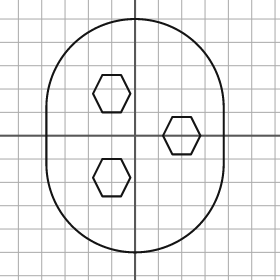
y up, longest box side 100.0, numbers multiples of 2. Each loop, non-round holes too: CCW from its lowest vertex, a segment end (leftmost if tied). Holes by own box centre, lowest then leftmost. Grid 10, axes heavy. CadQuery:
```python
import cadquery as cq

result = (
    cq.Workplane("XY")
    .moveTo(-38.0, -12.0)
    .threePointArc((0.0, -50.0), (38.0, -12.0))
    .lineTo(38.0, 12.0)
    .threePointArc((0.0, 50.0), (-38.0, 12.0))
    .close()
    .moveTo(-14.0, -26.0)
    .lineTo(-6.0, -26.0)
    .lineTo(-2.0, -18.0)
    .lineTo(-6.0, -10.0)
    .lineTo(-14.0, -10.0)
    .lineTo(-18.0, -18.0)
    .close()
    .moveTo(16.0, -8.0)
    .lineTo(24.0, -8.0)
    .lineTo(28.0, 0.0)
    .lineTo(24.0, 8.0)
    .lineTo(16.0, 8.0)
    .lineTo(12.0, 0.0)
    .close()
    .moveTo(-14.0, 10.0)
    .lineTo(-6.0, 10.0)
    .lineTo(-2.0, 18.0)
    .lineTo(-6.0, 26.0)
    .lineTo(-14.0, 26.0)
    .lineTo(-18.0, 18.0)
    .close()
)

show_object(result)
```